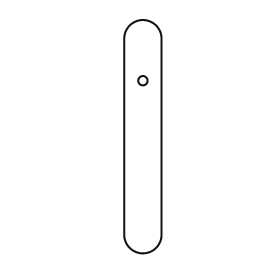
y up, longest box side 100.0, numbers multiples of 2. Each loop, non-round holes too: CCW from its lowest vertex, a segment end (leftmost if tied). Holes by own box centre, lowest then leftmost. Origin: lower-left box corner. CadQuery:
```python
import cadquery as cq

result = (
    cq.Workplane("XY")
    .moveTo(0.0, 8.0)
    .threePointArc((8.0, 0.0), (16.0, 8.0))
    .lineTo(16.0, 92.0)
    .threePointArc((8.0, 100.0), (0.0, 92.0))
    .close()
    .moveTo(8.0, 74.0)
    .circle(2.0)
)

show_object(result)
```